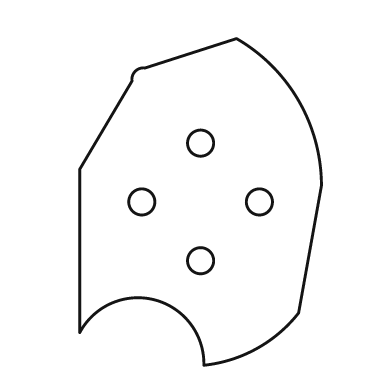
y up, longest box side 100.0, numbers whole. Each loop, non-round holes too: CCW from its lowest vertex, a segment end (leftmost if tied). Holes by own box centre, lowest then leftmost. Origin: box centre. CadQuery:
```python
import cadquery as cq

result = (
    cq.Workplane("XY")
    .moveTo(1.0, -50.0)
    .threePointArc((17.0, -45.0), (30.0, -34.0))
    .lineTo(37.0, 5.0)
    .threePointArc((30.0, 31.0), (11.0, 50.0))
    .lineTo(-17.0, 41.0)
    .threePointArc((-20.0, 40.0), (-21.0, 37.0))
    .lineTo(-37.0, 10.0)
    .lineTo(-37.0, -40.0)
    .threePointArc((-14.0, -30.0), (1.0, -50.0))
    .close()
    .moveTo(0.0, -18.0)
    .circle(4.0)
    .moveTo(-18.0, 0.0)
    .circle(4.0)
    .moveTo(18.0, 0.0)
    .circle(4.0)
    .moveTo(0.0, 18.0)
    .circle(4.0)
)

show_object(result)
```